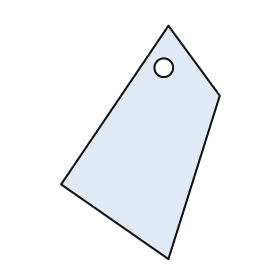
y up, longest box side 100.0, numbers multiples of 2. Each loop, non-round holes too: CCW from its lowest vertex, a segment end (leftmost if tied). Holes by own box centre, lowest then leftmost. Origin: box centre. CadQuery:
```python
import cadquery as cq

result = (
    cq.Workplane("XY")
    .moveTo(12.0, -50.0)
    .lineTo(34.0, 20.0)
    .lineTo(12.0, 50.0)
    .lineTo(-34.0, -18.0)
    .close()
    .moveTo(10.0, 32.0)
    .circle(4.0)
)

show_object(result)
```